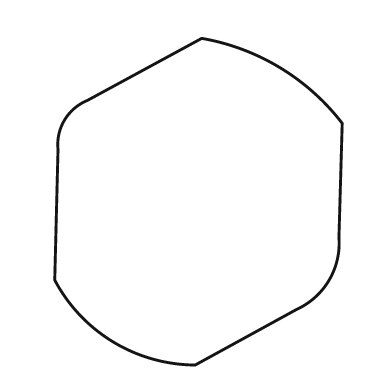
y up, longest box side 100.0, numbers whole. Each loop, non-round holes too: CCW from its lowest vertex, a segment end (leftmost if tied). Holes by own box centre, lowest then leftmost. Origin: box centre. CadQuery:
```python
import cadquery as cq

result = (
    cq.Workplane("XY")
    .moveTo(-1.0, -50.0)
    .lineTo(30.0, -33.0)
    .threePointArc((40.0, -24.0), (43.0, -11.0))
    .lineTo(44.0, 24.0)
    .threePointArc((25.0, 41.0), (1.0, 50.0))
    .lineTo(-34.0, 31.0)
    .threePointArc((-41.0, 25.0), (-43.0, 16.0))
    .lineTo(-44.0, -24.0)
    .threePointArc((-26.0, -43.0), (-1.0, -50.0))
    .close()
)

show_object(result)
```